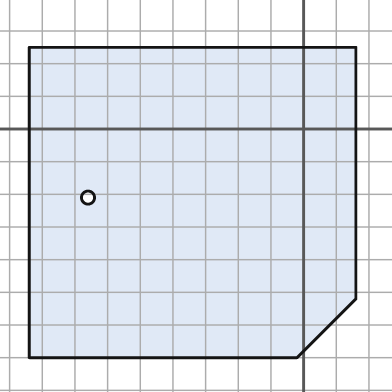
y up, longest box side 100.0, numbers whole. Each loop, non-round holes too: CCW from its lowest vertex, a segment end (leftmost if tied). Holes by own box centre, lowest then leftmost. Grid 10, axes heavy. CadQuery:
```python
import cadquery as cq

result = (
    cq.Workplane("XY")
    .moveTo(-84.0, -70.0)
    .lineTo(-2.0, -70.0)
    .lineTo(16.0, -52.0)
    .lineTo(16.0, 25.0)
    .lineTo(-84.0, 25.0)
    .close()
    .moveTo(-66.0, -21.0)
    .circle(2.0)
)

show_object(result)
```